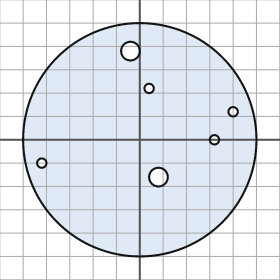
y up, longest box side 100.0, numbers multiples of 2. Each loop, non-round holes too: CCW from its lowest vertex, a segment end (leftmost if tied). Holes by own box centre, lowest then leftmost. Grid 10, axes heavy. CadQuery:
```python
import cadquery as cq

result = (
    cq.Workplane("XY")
    .moveTo(0.0, 0.0)
    .circle(50.0)
    .moveTo(8.0, -16.0)
    .circle(4.0)
    .moveTo(-42.0, -10.0)
    .circle(2.0)
    .moveTo(32.0, 0.0)
    .circle(2.0)
    .moveTo(40.0, 12.0)
    .circle(2.0)
    .moveTo(4.0, 22.0)
    .circle(2.0)
    .moveTo(-4.0, 38.0)
    .circle(4.0)
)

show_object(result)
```